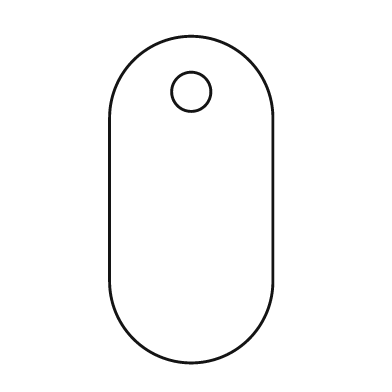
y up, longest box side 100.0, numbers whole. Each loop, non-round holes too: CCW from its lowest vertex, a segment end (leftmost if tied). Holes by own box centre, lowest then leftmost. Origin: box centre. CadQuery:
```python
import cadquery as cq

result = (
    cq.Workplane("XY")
    .moveTo(-25.0, -25.0)
    .threePointArc((0.0, -50.0), (25.0, -25.0))
    .lineTo(25.0, 25.0)
    .threePointArc((0.0, 50.0), (-25.0, 25.0))
    .close()
    .moveTo(0.0, 33.0)
    .circle(6.0)
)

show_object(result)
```